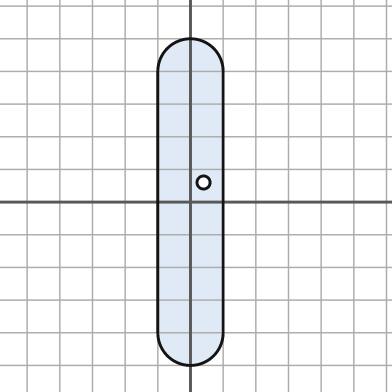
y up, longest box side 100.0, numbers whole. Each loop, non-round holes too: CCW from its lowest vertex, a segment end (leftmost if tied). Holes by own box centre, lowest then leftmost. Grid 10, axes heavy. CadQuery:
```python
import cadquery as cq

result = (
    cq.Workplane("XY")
    .moveTo(-10.0, -40.0)
    .threePointArc((0.0, -50.0), (10.0, -40.0))
    .lineTo(10.0, 40.0)
    .threePointArc((0.0, 50.0), (-10.0, 40.0))
    .close()
    .moveTo(4.0, 6.0)
    .circle(2.0)
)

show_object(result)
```